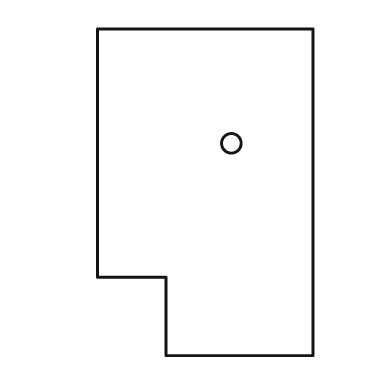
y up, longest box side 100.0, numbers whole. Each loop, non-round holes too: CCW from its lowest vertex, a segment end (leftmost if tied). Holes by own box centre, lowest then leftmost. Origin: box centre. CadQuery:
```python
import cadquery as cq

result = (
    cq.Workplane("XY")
    .moveTo(-12.0, -50.0)
    .lineTo(33.0, -50.0)
    .lineTo(33.0, 50.0)
    .lineTo(-33.0, 50.0)
    .lineTo(-33.0, -26.0)
    .lineTo(-12.0, -26.0)
    .close()
    .moveTo(8.0, 15.0)
    .circle(3.0)
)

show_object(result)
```